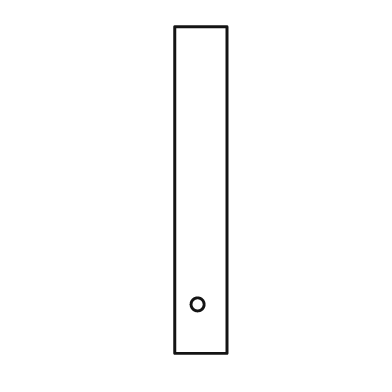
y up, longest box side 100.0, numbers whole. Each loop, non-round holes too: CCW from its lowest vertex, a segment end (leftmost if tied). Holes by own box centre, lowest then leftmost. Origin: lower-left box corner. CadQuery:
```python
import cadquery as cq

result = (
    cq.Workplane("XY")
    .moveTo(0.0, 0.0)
    .lineTo(16.0, 0.0)
    .lineTo(16.0, 100.0)
    .lineTo(0.0, 100.0)
    .close()
    .moveTo(7.0, 15.0)
    .circle(2.0)
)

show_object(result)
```